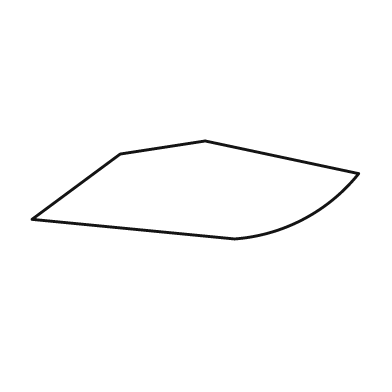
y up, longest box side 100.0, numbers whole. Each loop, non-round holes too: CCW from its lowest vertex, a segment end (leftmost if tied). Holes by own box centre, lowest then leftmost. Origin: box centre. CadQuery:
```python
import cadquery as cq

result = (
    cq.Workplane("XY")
    .moveTo(12.0, -15.0)
    .threePointArc((33.0, -9.0), (50.0, 5.0))
    .lineTo(3.0, 15.0)
    .lineTo(-23.0, 11.0)
    .lineTo(-50.0, -9.0)
    .close()
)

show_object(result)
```